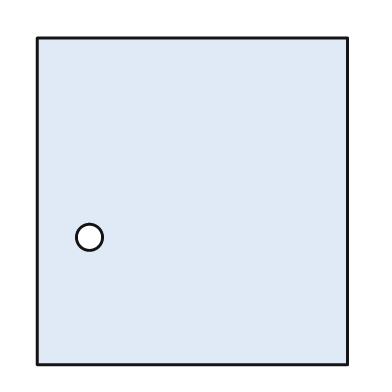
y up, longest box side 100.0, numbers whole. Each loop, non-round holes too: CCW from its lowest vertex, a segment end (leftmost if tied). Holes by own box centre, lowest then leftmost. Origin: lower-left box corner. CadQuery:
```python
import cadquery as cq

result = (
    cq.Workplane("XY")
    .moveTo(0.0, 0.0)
    .lineTo(95.0, 0.0)
    .lineTo(95.0, 100.0)
    .lineTo(0.0, 100.0)
    .close()
    .moveTo(16.0, 39.0)
    .circle(4.0)
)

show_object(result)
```